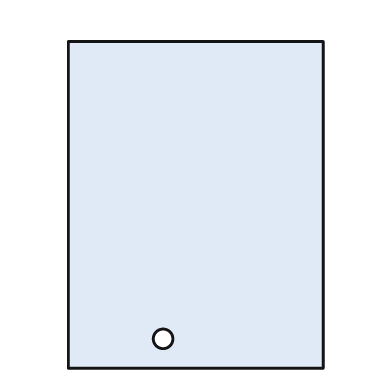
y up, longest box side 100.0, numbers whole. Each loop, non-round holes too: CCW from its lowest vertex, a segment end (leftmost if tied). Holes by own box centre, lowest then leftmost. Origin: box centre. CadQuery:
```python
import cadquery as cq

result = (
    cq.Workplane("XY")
    .moveTo(-39.0, -50.0)
    .lineTo(39.0, -50.0)
    .lineTo(39.0, 50.0)
    .lineTo(-39.0, 50.0)
    .close()
    .moveTo(-10.0, -41.0)
    .circle(3.0)
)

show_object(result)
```